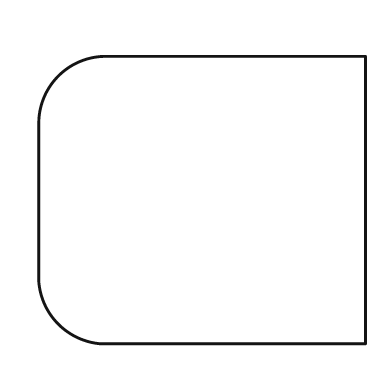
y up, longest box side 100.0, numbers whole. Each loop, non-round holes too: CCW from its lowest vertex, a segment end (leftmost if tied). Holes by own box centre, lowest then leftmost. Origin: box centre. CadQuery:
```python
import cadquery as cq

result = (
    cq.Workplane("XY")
    .moveTo(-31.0, -44.0)
    .lineTo(50.0, -44.0)
    .lineTo(50.0, 44.0)
    .lineTo(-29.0, 44.0)
    .threePointArc((-44.0, 38.0), (-50.0, 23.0))
    .lineTo(-50.0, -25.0)
    .threePointArc((-44.0, -38.0), (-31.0, -44.0))
    .close()
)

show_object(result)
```